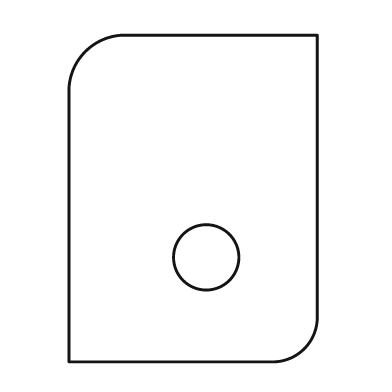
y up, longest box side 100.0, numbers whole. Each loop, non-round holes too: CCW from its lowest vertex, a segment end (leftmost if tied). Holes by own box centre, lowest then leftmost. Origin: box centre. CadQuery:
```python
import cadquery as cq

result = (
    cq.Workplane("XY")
    .moveTo(-38.0, -50.0)
    .lineTo(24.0, -50.0)
    .threePointArc((34.0, -46.0), (38.0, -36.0))
    .lineTo(38.0, 50.0)
    .lineTo(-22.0, 50.0)
    .threePointArc((-33.0, 45.0), (-38.0, 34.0))
    .close()
    .moveTo(4.0, -18.0)
    .circle(10.0)
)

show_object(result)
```